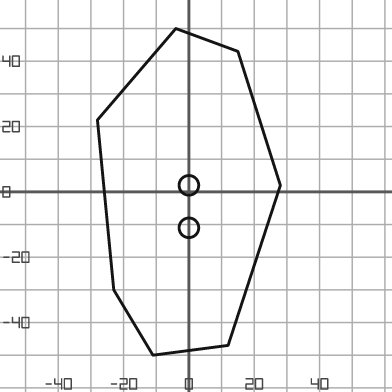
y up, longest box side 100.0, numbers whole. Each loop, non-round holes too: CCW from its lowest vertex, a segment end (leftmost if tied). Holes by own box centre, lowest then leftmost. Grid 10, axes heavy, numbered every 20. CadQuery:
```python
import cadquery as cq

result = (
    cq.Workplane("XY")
    .moveTo(-11.0, -50.0)
    .lineTo(12.0, -47.0)
    .lineTo(28.0, 2.0)
    .lineTo(15.0, 43.0)
    .lineTo(-4.0, 50.0)
    .lineTo(-28.0, 22.0)
    .lineTo(-23.0, -30.0)
    .close()
    .moveTo(0.0, -11.0)
    .circle(3.0)
    .moveTo(0.0, 2.0)
    .circle(3.0)
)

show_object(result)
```